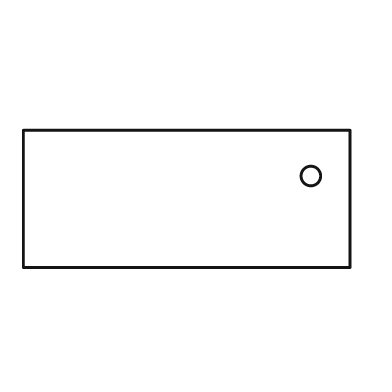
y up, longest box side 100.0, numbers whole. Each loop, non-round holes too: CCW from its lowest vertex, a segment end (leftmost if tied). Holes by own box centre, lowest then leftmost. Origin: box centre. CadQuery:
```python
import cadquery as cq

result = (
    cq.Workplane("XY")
    .moveTo(-50.0, -21.0)
    .lineTo(50.0, -21.0)
    .lineTo(50.0, 21.0)
    .lineTo(-50.0, 21.0)
    .close()
    .moveTo(38.0, 7.0)
    .circle(3.0)
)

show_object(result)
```